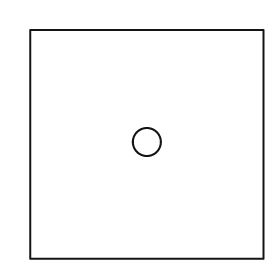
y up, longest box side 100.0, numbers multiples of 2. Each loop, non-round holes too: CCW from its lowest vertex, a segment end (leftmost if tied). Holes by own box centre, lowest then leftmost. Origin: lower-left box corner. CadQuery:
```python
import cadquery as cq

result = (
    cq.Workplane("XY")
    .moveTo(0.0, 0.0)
    .lineTo(100.0, 0.0)
    .lineTo(100.0, 98.0)
    .lineTo(0.0, 98.0)
    .close()
    .moveTo(50.0, 50.0)
    .circle(6.0)
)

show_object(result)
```